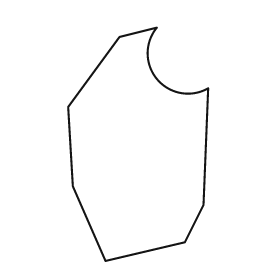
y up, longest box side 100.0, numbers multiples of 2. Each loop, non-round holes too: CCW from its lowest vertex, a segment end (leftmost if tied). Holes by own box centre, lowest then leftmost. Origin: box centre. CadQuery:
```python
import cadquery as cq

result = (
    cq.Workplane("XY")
    .moveTo(-14.0, -50.0)
    .lineTo(20.0, -42.0)
    .lineTo(28.0, -26.0)
    .lineTo(30.0, 24.0)
    .threePointArc((8.0, 28.0), (8.0, 50.0))
    .lineTo(-8.0, 46.0)
    .lineTo(-30.0, 16.0)
    .lineTo(-28.0, -18.0)
    .close()
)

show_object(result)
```